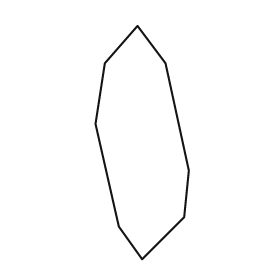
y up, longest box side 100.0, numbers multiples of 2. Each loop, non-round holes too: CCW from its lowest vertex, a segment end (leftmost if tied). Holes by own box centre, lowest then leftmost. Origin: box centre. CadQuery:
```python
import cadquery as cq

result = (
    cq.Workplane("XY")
    .moveTo(0.0, -50.0)
    .lineTo(18.0, -32.0)
    .lineTo(20.0, -12.0)
    .lineTo(10.0, 34.0)
    .lineTo(-2.0, 50.0)
    .lineTo(-16.0, 34.0)
    .lineTo(-20.0, 8.0)
    .lineTo(-10.0, -36.0)
    .close()
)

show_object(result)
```